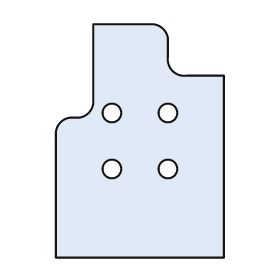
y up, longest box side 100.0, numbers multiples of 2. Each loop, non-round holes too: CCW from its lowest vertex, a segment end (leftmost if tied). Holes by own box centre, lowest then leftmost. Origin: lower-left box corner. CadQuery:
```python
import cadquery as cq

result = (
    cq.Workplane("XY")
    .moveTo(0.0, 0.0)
    .lineTo(72.0, 0.0)
    .lineTo(72.0, 78.0)
    .lineTo(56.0, 78.0)
    .threePointArc((50.0, 80.0), (48.0, 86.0))
    .lineTo(48.0, 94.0)
    .threePointArc((46.0, 98.0), (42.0, 100.0))
    .lineTo(16.0, 100.0)
    .lineTo(16.0, 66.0)
    .threePointArc((14.0, 62.0), (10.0, 60.0))
    .lineTo(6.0, 60.0)
    .threePointArc((2.0, 58.0), (0.0, 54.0))
    .close()
    .moveTo(24.0, 38.0)
    .circle(4.0)
    .moveTo(48.0, 38.0)
    .circle(4.0)
    .moveTo(24.0, 62.0)
    .circle(4.0)
    .moveTo(48.0, 62.0)
    .circle(4.0)
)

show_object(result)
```